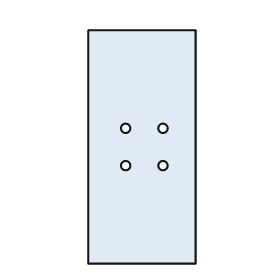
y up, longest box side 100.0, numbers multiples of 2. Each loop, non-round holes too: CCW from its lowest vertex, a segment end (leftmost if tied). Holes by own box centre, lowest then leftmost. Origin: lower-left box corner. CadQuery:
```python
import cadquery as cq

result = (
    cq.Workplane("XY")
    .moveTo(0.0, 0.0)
    .lineTo(46.0, 0.0)
    .lineTo(46.0, 100.0)
    .lineTo(0.0, 100.0)
    .close()
    .moveTo(16.0, 42.0)
    .circle(2.0)
    .moveTo(32.0, 42.0)
    .circle(2.0)
    .moveTo(16.0, 58.0)
    .circle(2.0)
    .moveTo(32.0, 58.0)
    .circle(2.0)
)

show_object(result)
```